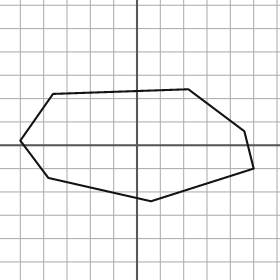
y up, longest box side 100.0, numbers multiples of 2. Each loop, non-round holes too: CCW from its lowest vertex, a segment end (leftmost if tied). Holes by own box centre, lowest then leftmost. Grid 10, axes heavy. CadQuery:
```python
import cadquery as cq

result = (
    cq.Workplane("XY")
    .moveTo(6.0, -24.0)
    .lineTo(50.0, -10.0)
    .lineTo(46.0, 6.0)
    .lineTo(22.0, 24.0)
    .lineTo(-36.0, 22.0)
    .lineTo(-50.0, 2.0)
    .lineTo(-38.0, -14.0)
    .close()
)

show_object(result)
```